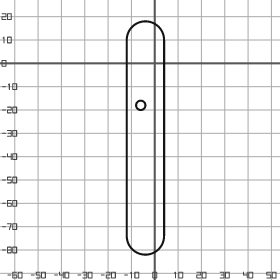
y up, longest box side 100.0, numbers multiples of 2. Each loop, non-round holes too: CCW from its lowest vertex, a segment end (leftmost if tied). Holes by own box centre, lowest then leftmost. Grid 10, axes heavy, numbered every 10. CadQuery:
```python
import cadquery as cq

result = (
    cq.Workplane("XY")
    .moveTo(-12.0, -74.0)
    .threePointArc((-4.0, -82.0), (4.0, -74.0))
    .lineTo(4.0, 10.0)
    .threePointArc((-4.0, 18.0), (-12.0, 10.0))
    .close()
    .moveTo(-6.0, -18.0)
    .circle(2.0)
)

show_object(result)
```